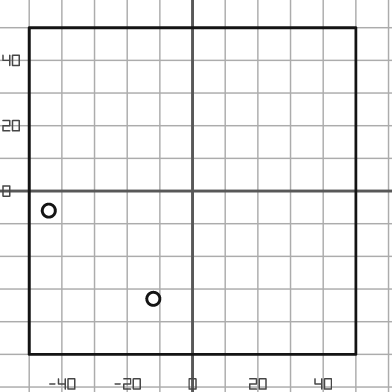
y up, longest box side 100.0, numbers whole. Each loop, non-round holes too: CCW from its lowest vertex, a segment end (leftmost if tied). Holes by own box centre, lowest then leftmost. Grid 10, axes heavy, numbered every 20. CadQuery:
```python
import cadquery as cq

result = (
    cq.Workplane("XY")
    .moveTo(-50.0, -50.0)
    .lineTo(50.0, -50.0)
    .lineTo(50.0, 50.0)
    .lineTo(-50.0, 50.0)
    .close()
    .moveTo(-12.0, -33.0)
    .circle(2.0)
    .moveTo(-44.0, -6.0)
    .circle(2.0)
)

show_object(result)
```